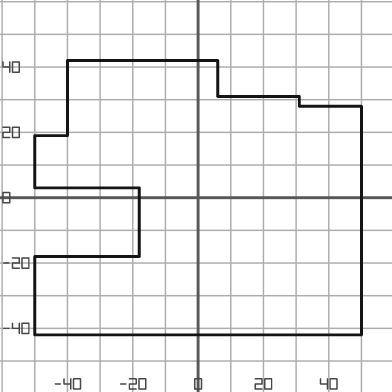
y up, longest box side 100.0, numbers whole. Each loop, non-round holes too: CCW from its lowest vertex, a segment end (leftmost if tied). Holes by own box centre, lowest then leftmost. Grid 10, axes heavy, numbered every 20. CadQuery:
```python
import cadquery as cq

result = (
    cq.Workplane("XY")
    .moveTo(-50.0, -42.0)
    .lineTo(50.0, -42.0)
    .lineTo(50.0, 28.0)
    .lineTo(31.0, 28.0)
    .lineTo(31.0, 31.0)
    .lineTo(6.0, 31.0)
    .lineTo(6.0, 42.0)
    .lineTo(-40.0, 42.0)
    .lineTo(-40.0, 19.0)
    .lineTo(-50.0, 19.0)
    .lineTo(-50.0, 3.0)
    .lineTo(-18.0, 3.0)
    .lineTo(-18.0, -18.0)
    .lineTo(-50.0, -18.0)
    .close()
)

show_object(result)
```